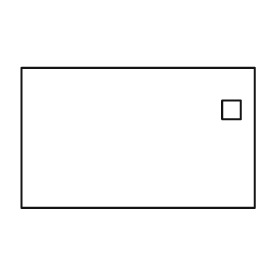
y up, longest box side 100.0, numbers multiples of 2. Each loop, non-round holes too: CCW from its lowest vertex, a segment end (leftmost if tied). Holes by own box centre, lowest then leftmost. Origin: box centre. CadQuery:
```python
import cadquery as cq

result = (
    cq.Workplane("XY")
    .moveTo(-50.0, -30.0)
    .lineTo(50.0, -30.0)
    .lineTo(50.0, 30.0)
    .lineTo(-50.0, 30.0)
    .close()
    .moveTo(36.0, 8.0)
    .lineTo(44.0, 8.0)
    .lineTo(44.0, 16.0)
    .lineTo(36.0, 16.0)
    .close()
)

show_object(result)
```